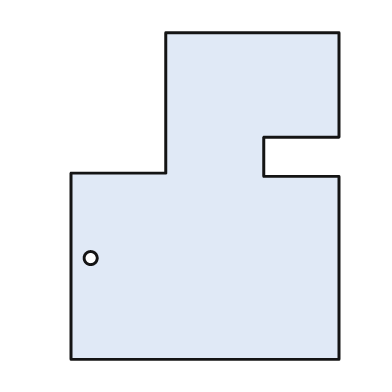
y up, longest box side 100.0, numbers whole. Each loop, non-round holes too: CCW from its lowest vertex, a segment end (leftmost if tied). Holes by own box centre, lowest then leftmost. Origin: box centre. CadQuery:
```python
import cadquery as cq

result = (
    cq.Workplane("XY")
    .moveTo(-41.0, -50.0)
    .lineTo(41.0, -50.0)
    .lineTo(41.0, 6.0)
    .lineTo(18.0, 6.0)
    .lineTo(18.0, 18.0)
    .lineTo(41.0, 18.0)
    .lineTo(41.0, 50.0)
    .lineTo(-12.0, 50.0)
    .lineTo(-12.0, 7.0)
    .lineTo(-41.0, 7.0)
    .close()
    .moveTo(-35.0, -19.0)
    .circle(2.0)
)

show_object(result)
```